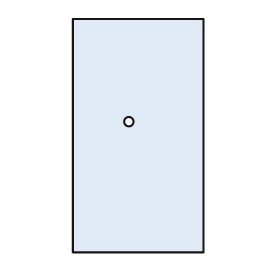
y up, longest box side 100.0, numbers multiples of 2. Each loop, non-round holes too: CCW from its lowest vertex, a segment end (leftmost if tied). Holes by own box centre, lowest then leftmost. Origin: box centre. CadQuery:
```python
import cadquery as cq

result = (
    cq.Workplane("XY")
    .moveTo(-28.0, -50.0)
    .lineTo(28.0, -50.0)
    .lineTo(28.0, 50.0)
    .lineTo(-28.0, 50.0)
    .close()
    .moveTo(-4.0, 6.0)
    .circle(2.0)
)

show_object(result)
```